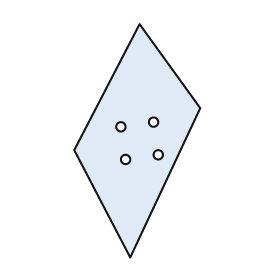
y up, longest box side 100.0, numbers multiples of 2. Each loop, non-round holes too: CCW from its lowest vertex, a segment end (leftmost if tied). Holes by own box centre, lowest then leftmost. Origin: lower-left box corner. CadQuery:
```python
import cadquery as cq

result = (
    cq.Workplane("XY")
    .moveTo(24.0, 0.0)
    .lineTo(54.0, 64.0)
    .lineTo(28.0, 100.0)
    .lineTo(0.0, 46.0)
    .close()
    .moveTo(22.0, 42.0)
    .circle(2.0)
    .moveTo(36.0, 44.0)
    .circle(2.0)
    .moveTo(20.0, 56.0)
    .circle(2.0)
    .moveTo(34.0, 58.0)
    .circle(2.0)
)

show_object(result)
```